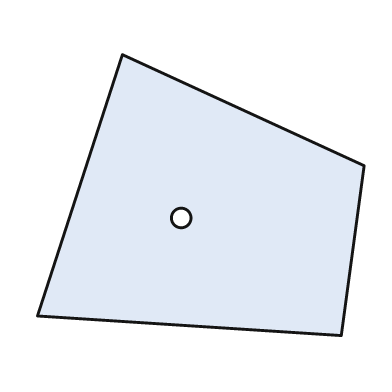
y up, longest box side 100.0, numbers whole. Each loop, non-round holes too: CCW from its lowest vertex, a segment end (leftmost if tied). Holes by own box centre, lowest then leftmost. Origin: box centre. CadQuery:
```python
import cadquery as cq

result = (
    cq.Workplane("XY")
    .moveTo(43.0, -43.0)
    .lineTo(50.0, 9.0)
    .lineTo(-24.0, 43.0)
    .lineTo(-50.0, -37.0)
    .close()
    .moveTo(-6.0, -7.0)
    .circle(3.0)
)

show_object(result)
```